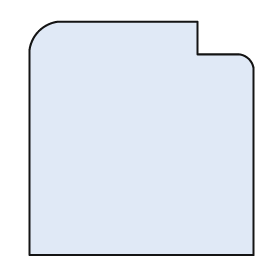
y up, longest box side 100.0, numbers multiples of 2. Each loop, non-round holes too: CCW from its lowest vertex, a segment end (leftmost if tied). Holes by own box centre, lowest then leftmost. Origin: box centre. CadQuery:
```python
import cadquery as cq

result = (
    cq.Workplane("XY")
    .moveTo(-48.0, -50.0)
    .lineTo(48.0, -50.0)
    .lineTo(48.0, 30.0)
    .threePointArc((46.0, 34.0), (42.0, 36.0))
    .lineTo(24.0, 36.0)
    .lineTo(24.0, 50.0)
    .lineTo(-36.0, 50.0)
    .threePointArc((-44.0, 46.0), (-48.0, 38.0))
    .close()
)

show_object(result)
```